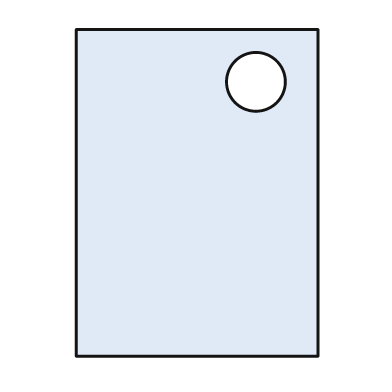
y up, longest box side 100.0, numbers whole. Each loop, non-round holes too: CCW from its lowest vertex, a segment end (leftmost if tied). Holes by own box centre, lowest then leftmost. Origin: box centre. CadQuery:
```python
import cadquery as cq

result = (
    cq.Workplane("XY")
    .moveTo(-37.0, -50.0)
    .lineTo(37.0, -50.0)
    .lineTo(37.0, 50.0)
    .lineTo(-37.0, 50.0)
    .close()
    .moveTo(18.0, 34.0)
    .circle(9.0)
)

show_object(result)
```